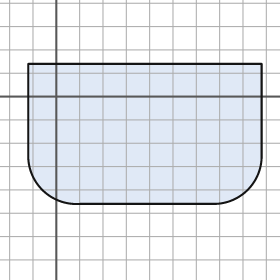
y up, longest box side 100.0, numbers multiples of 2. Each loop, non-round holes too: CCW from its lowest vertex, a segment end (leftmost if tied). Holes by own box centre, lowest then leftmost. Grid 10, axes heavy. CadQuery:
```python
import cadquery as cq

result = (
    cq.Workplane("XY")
    .moveTo(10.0, -46.0)
    .lineTo(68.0, -46.0)
    .threePointArc((82.0, -40.0), (88.0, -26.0))
    .lineTo(88.0, 14.0)
    .lineTo(-12.0, 14.0)
    .lineTo(-12.0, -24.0)
    .threePointArc((-6.0, -40.0), (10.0, -46.0))
    .close()
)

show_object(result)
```